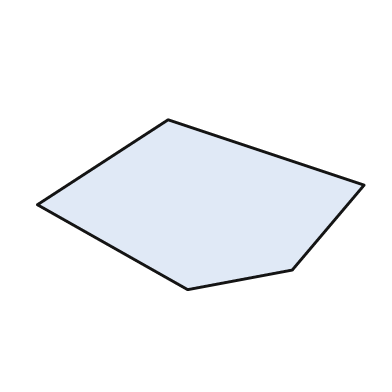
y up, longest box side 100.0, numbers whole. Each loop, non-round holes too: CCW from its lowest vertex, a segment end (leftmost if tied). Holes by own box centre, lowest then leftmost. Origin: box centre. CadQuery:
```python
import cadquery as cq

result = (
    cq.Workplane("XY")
    .moveTo(-4.0, -26.0)
    .lineTo(28.0, -20.0)
    .lineTo(50.0, 6.0)
    .lineTo(-10.0, 26.0)
    .lineTo(-50.0, 0.0)
    .close()
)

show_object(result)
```